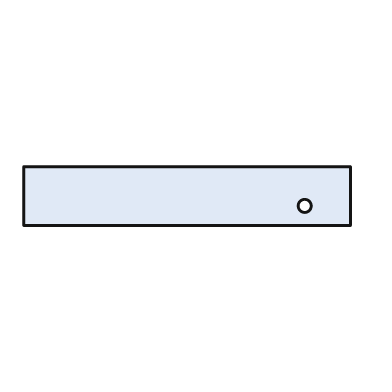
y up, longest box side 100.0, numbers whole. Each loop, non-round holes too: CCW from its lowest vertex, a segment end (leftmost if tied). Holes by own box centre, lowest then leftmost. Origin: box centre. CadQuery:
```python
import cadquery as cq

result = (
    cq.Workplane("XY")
    .moveTo(-50.0, -9.0)
    .lineTo(50.0, -9.0)
    .lineTo(50.0, 9.0)
    .lineTo(-50.0, 9.0)
    .close()
    .moveTo(36.0, -3.0)
    .circle(2.0)
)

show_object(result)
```